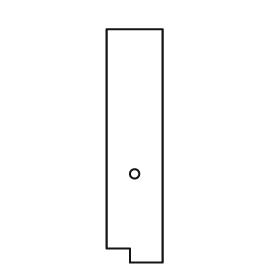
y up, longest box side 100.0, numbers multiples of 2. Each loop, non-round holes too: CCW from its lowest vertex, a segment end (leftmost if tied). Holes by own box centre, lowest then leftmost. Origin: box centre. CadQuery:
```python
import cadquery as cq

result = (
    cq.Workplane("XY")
    .moveTo(-2.0, -50.0)
    .lineTo(12.0, -50.0)
    .lineTo(12.0, 50.0)
    .lineTo(-12.0, 50.0)
    .lineTo(-12.0, -44.0)
    .lineTo(-2.0, -44.0)
    .close()
    .moveTo(0.0, -12.0)
    .circle(2.0)
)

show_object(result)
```